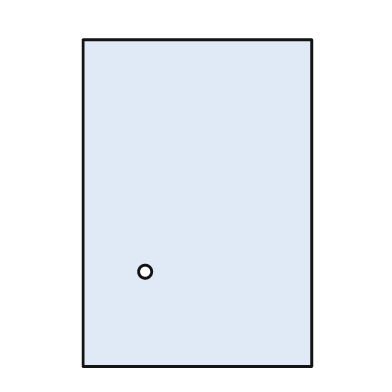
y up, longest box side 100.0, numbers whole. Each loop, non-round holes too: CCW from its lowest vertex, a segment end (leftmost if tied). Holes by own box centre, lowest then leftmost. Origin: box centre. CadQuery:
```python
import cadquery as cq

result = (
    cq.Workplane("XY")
    .moveTo(-35.0, -50.0)
    .lineTo(35.0, -50.0)
    .lineTo(35.0, 50.0)
    .lineTo(-35.0, 50.0)
    .close()
    .moveTo(-16.0, -21.0)
    .circle(2.0)
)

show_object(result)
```